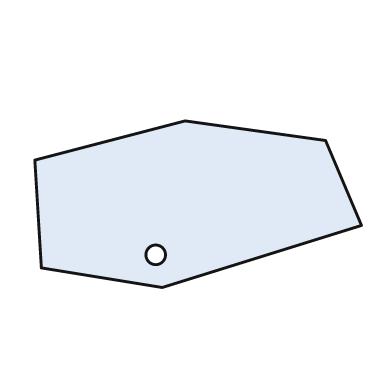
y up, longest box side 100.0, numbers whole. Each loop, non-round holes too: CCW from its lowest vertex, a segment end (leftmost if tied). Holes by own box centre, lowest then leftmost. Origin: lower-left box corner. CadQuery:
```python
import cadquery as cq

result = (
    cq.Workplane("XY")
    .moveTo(39.0, 0.0)
    .lineTo(100.0, 19.0)
    .lineTo(89.0, 45.0)
    .lineTo(46.0, 51.0)
    .lineTo(0.0, 39.0)
    .lineTo(2.0, 6.0)
    .close()
    .moveTo(37.0, 10.0)
    .circle(3.0)
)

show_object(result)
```